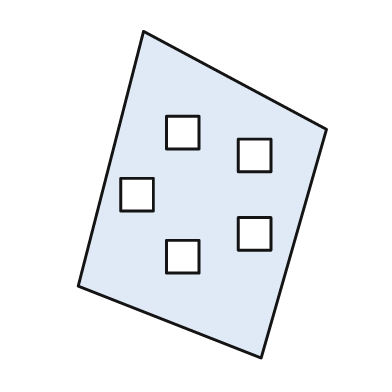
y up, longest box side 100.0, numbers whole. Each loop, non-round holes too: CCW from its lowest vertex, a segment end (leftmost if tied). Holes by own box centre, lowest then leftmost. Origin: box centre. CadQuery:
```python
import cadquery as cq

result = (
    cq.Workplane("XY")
    .moveTo(18.0, -50.0)
    .lineTo(38.0, 20.0)
    .lineTo(-18.0, 50.0)
    .lineTo(-38.0, -28.0)
    .close()
    .moveTo(-11.0, -24.0)
    .lineTo(-1.0, -24.0)
    .lineTo(-1.0, -14.0)
    .lineTo(-11.0, -14.0)
    .close()
    .moveTo(11.0, -17.0)
    .lineTo(21.0, -17.0)
    .lineTo(21.0, -7.0)
    .lineTo(11.0, -7.0)
    .close()
    .moveTo(-25.0, -5.0)
    .lineTo(-15.0, -5.0)
    .lineTo(-15.0, 5.0)
    .lineTo(-25.0, 5.0)
    .close()
    .moveTo(11.0, 7.0)
    .lineTo(21.0, 7.0)
    .lineTo(21.0, 17.0)
    .lineTo(11.0, 17.0)
    .close()
    .moveTo(-11.0, 14.0)
    .lineTo(-1.0, 14.0)
    .lineTo(-1.0, 24.0)
    .lineTo(-11.0, 24.0)
    .close()
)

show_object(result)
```